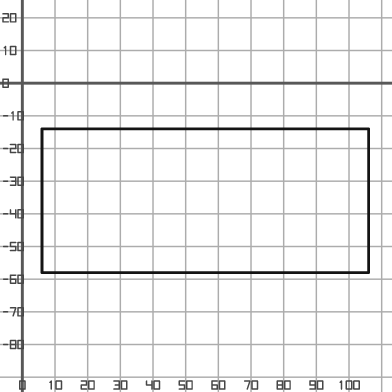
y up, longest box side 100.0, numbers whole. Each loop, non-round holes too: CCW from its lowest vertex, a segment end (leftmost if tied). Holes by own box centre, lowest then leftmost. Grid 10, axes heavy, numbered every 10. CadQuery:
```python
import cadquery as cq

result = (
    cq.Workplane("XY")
    .moveTo(6.0, -58.0)
    .lineTo(106.0, -58.0)
    .lineTo(106.0, -14.0)
    .lineTo(6.0, -14.0)
    .close()
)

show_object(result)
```